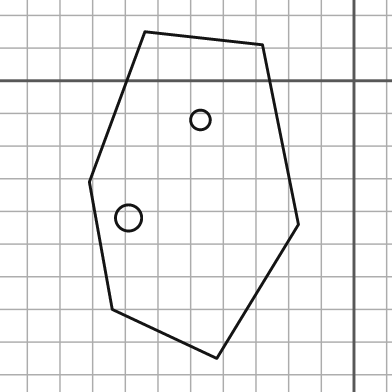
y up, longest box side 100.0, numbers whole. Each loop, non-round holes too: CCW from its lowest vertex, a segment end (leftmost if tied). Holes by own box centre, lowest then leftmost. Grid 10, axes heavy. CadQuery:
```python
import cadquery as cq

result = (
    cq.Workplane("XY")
    .moveTo(-42.0, -85.0)
    .lineTo(-17.0, -44.0)
    .lineTo(-28.0, 11.0)
    .lineTo(-64.0, 15.0)
    .lineTo(-81.0, -31.0)
    .lineTo(-74.0, -70.0)
    .close()
    .moveTo(-69.0, -42.0)
    .circle(4.0)
    .moveTo(-47.0, -12.0)
    .circle(3.0)
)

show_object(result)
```